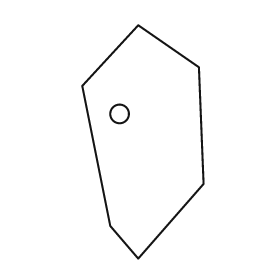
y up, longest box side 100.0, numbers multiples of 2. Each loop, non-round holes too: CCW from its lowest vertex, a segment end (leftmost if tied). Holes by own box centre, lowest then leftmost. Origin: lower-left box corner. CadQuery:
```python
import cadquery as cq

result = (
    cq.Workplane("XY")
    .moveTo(24.0, 0.0)
    .lineTo(52.0, 32.0)
    .lineTo(50.0, 82.0)
    .lineTo(24.0, 100.0)
    .lineTo(0.0, 74.0)
    .lineTo(12.0, 14.0)
    .close()
    .moveTo(16.0, 62.0)
    .circle(4.0)
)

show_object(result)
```